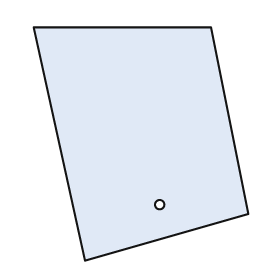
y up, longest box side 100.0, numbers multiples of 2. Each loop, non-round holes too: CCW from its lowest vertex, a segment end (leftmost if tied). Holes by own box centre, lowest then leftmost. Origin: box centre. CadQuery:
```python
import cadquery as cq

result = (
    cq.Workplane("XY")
    .moveTo(-24.0, -50.0)
    .lineTo(46.0, -30.0)
    .lineTo(30.0, 50.0)
    .lineTo(-46.0, 50.0)
    .close()
    .moveTo(8.0, -26.0)
    .circle(2.0)
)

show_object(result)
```